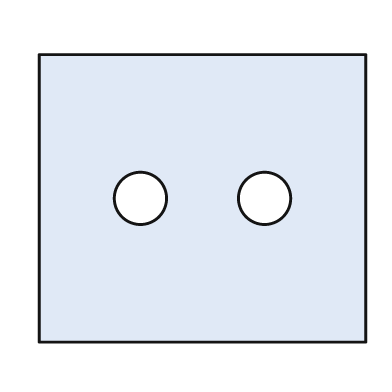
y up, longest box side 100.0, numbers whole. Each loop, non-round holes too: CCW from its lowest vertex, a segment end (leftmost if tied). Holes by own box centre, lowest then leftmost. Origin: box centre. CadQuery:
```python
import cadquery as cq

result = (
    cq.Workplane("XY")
    .moveTo(-50.0, -44.0)
    .lineTo(50.0, -44.0)
    .lineTo(50.0, 44.0)
    .lineTo(-50.0, 44.0)
    .close()
    .moveTo(-19.0, 0.0)
    .circle(8.0)
    .moveTo(19.0, 0.0)
    .circle(8.0)
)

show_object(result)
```